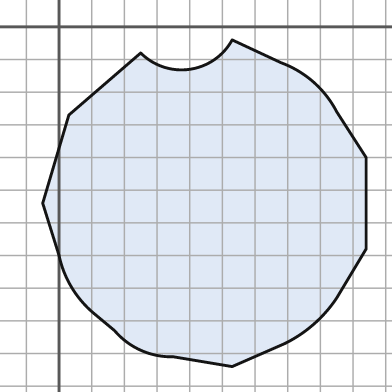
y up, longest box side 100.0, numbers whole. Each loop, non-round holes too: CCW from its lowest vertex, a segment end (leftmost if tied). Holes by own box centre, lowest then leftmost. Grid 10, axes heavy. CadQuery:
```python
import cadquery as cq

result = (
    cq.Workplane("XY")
    .moveTo(53.0, -104.0)
    .lineTo(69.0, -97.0)
    .threePointArc((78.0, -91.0), (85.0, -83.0))
    .lineTo(94.0, -68.0)
    .lineTo(94.0, -40.0)
    .lineTo(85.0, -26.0)
    .threePointArc((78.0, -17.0), (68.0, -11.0))
    .lineTo(53.0, -4.0)
    .threePointArc((40.0, -13.0), (25.0, -8.0))
    .lineTo(3.0, -27.0)
    .lineTo(-5.0, -54.0)
    .lineTo(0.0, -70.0)
    .threePointArc((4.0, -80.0), (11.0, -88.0))
    .lineTo(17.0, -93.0)
    .threePointArc((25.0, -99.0), (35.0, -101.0))
    .close()
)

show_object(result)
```